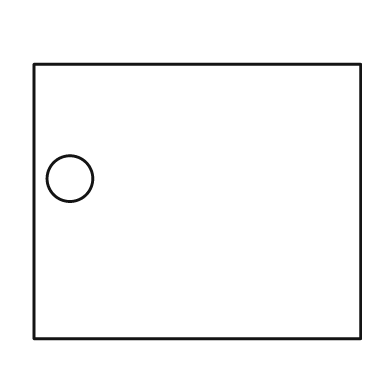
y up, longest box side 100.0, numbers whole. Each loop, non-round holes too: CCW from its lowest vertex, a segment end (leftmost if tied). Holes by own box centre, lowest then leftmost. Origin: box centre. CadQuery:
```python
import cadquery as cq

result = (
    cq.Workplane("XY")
    .moveTo(-50.0, -42.0)
    .lineTo(50.0, -42.0)
    .lineTo(50.0, 42.0)
    .lineTo(-50.0, 42.0)
    .close()
    .moveTo(-39.0, 7.0)
    .circle(7.0)
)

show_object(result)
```